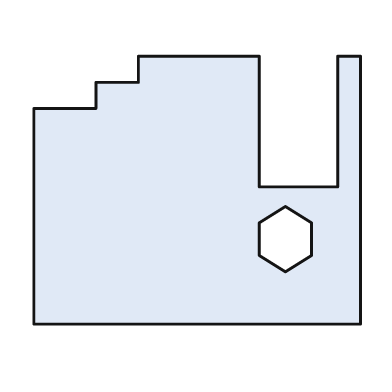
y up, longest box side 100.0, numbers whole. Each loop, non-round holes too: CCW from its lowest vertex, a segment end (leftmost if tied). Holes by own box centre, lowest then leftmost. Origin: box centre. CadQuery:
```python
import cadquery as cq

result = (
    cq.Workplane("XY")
    .moveTo(-50.0, -41.0)
    .lineTo(50.0, -41.0)
    .lineTo(50.0, 41.0)
    .lineTo(43.0, 41.0)
    .lineTo(43.0, 1.0)
    .lineTo(19.0, 1.0)
    .lineTo(19.0, 41.0)
    .lineTo(-18.0, 41.0)
    .lineTo(-18.0, 33.0)
    .lineTo(-31.0, 33.0)
    .lineTo(-31.0, 25.0)
    .lineTo(-50.0, 25.0)
    .close()
    .moveTo(27.0, -25.0)
    .lineTo(35.0, -20.0)
    .lineTo(35.0, -10.0)
    .lineTo(27.0, -5.0)
    .lineTo(19.0, -10.0)
    .lineTo(19.0, -20.0)
    .close()
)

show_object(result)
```